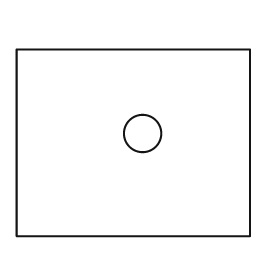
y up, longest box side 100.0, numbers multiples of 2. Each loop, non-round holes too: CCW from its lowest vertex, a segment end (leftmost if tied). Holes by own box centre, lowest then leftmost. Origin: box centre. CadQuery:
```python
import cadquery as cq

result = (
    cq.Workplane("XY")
    .moveTo(-50.0, -40.0)
    .lineTo(50.0, -40.0)
    .lineTo(50.0, 40.0)
    .lineTo(-50.0, 40.0)
    .close()
    .moveTo(4.0, 4.0)
    .circle(8.0)
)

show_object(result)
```